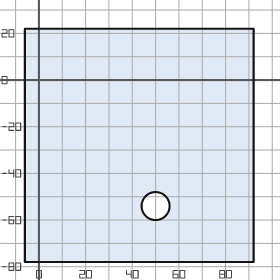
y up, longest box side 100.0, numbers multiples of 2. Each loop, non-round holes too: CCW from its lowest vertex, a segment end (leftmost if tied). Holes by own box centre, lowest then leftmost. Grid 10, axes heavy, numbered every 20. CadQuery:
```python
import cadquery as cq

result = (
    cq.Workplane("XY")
    .moveTo(-6.0, -78.0)
    .lineTo(92.0, -78.0)
    .lineTo(92.0, 22.0)
    .lineTo(-6.0, 22.0)
    .close()
    .moveTo(50.0, -54.0)
    .circle(6.0)
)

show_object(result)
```